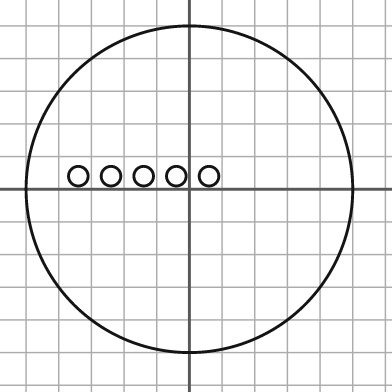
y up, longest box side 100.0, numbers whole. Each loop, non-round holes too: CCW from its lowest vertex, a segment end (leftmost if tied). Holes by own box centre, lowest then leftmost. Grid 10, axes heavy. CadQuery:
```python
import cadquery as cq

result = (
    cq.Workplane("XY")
    .moveTo(0.0, 0.0)
    .circle(50.0)
    .moveTo(-34.0, 4.0)
    .circle(3.0)
    .moveTo(-24.0, 4.0)
    .circle(3.0)
    .moveTo(-14.0, 4.0)
    .circle(3.0)
    .moveTo(-4.0, 4.0)
    .circle(3.0)
    .moveTo(6.0, 4.0)
    .circle(3.0)
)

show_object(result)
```